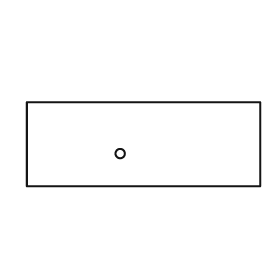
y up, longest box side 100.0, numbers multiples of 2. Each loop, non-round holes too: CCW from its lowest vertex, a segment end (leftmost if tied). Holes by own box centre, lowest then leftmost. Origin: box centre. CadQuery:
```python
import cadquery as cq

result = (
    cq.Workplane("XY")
    .moveTo(-50.0, -18.0)
    .lineTo(50.0, -18.0)
    .lineTo(50.0, 18.0)
    .lineTo(-50.0, 18.0)
    .close()
    .moveTo(-10.0, -4.0)
    .circle(2.0)
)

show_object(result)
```